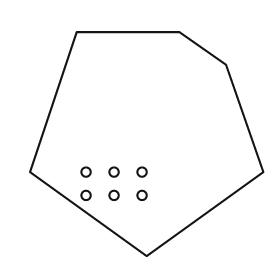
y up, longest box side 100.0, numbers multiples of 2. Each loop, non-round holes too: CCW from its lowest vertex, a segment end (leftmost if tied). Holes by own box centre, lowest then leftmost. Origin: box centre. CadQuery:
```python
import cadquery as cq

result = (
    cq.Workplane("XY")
    .moveTo(0.0, -48.0)
    .lineTo(50.0, -12.0)
    .lineTo(34.0, 34.0)
    .lineTo(14.0, 48.0)
    .lineTo(-30.0, 48.0)
    .lineTo(-50.0, -12.0)
    .close()
    .moveTo(-26.0, -22.0)
    .circle(2.0)
    .moveTo(-14.0, -22.0)
    .circle(2.0)
    .moveTo(-2.0, -22.0)
    .circle(2.0)
    .moveTo(-26.0, -12.0)
    .circle(2.0)
    .moveTo(-14.0, -12.0)
    .circle(2.0)
    .moveTo(-2.0, -12.0)
    .circle(2.0)
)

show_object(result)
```